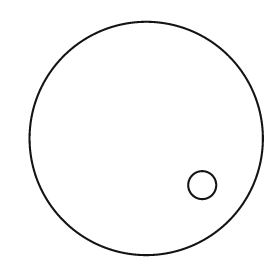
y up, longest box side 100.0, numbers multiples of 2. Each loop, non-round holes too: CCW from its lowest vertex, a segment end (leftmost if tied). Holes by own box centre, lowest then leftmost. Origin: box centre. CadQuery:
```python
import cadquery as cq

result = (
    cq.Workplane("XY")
    .moveTo(0.0, 0.0)
    .circle(50.0)
    .moveTo(24.0, -20.0)
    .circle(6.0)
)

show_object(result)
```